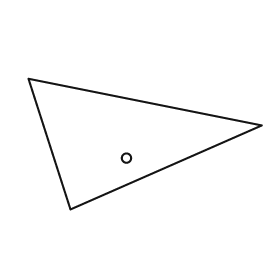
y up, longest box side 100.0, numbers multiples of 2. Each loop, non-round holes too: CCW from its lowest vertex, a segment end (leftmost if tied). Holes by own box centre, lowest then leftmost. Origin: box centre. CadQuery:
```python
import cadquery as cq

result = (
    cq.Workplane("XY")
    .moveTo(-32.0, -28.0)
    .lineTo(50.0, 8.0)
    .lineTo(-50.0, 28.0)
    .close()
    .moveTo(-8.0, -6.0)
    .circle(2.0)
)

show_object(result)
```